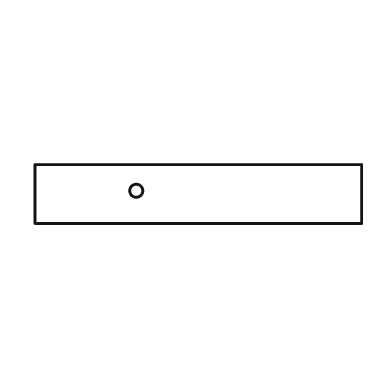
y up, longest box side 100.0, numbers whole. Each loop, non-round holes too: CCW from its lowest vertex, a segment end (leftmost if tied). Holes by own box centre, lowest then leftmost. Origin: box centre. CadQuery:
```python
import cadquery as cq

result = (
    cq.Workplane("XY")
    .moveTo(-50.0, -9.0)
    .lineTo(50.0, -9.0)
    .lineTo(50.0, 9.0)
    .lineTo(-50.0, 9.0)
    .close()
    .moveTo(-19.0, 1.0)
    .circle(2.0)
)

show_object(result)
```